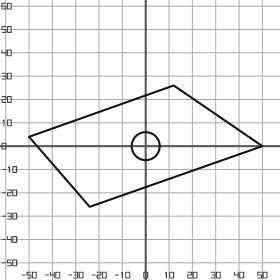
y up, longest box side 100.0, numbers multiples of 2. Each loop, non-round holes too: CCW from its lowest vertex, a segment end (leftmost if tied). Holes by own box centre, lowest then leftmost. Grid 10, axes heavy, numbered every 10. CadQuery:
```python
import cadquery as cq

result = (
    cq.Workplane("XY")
    .moveTo(-24.0, -26.0)
    .lineTo(50.0, 0.0)
    .lineTo(12.0, 26.0)
    .lineTo(-50.0, 4.0)
    .close()
    .moveTo(0.0, 0.0)
    .circle(6.0)
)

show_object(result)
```